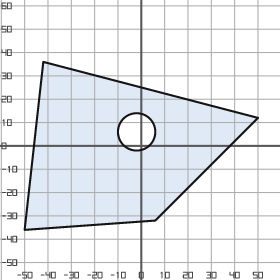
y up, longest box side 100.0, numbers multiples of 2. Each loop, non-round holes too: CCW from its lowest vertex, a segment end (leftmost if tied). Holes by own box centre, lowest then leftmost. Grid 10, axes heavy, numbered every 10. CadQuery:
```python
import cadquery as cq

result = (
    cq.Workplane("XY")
    .moveTo(-50.0, -36.0)
    .lineTo(6.0, -32.0)
    .lineTo(50.0, 12.0)
    .lineTo(-42.0, 36.0)
    .close()
    .moveTo(-2.0, 6.0)
    .circle(8.0)
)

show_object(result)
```